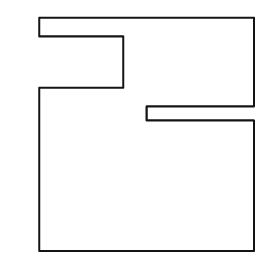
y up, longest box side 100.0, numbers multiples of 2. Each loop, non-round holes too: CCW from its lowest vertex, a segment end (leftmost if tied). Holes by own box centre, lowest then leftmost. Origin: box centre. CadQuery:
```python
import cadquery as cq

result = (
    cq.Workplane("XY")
    .moveTo(-46.0, -50.0)
    .lineTo(46.0, -50.0)
    .lineTo(46.0, 6.0)
    .lineTo(0.0, 6.0)
    .lineTo(0.0, 12.0)
    .lineTo(46.0, 12.0)
    .lineTo(46.0, 50.0)
    .lineTo(-46.0, 50.0)
    .lineTo(-46.0, 42.0)
    .lineTo(-10.0, 42.0)
    .lineTo(-10.0, 20.0)
    .lineTo(-46.0, 20.0)
    .close()
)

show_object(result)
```